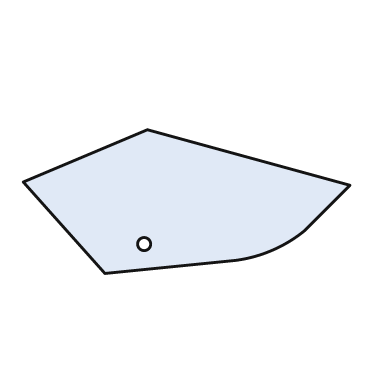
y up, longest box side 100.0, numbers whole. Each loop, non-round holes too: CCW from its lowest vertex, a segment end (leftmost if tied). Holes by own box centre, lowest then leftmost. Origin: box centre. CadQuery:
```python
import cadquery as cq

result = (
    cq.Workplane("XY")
    .moveTo(-25.0, -22.0)
    .lineTo(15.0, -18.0)
    .threePointArc((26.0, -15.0), (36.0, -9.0))
    .lineTo(50.0, 5.0)
    .lineTo(-12.0, 22.0)
    .lineTo(-50.0, 6.0)
    .close()
    .moveTo(-13.0, -13.0)
    .circle(2.0)
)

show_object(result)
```